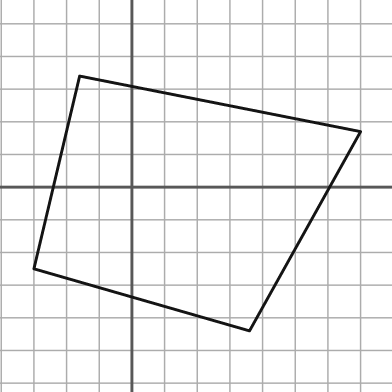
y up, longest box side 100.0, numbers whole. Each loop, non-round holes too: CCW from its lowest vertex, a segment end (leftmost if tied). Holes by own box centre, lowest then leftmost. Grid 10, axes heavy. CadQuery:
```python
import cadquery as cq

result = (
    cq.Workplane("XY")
    .moveTo(36.0, -44.0)
    .lineTo(70.0, 17.0)
    .lineTo(-16.0, 34.0)
    .lineTo(-30.0, -25.0)
    .close()
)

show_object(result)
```